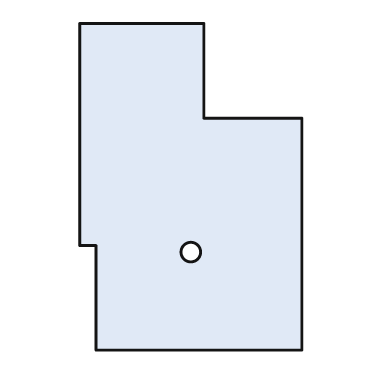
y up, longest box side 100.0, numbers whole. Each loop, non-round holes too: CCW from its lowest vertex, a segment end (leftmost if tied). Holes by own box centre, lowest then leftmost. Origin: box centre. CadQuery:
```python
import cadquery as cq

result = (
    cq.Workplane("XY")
    .moveTo(-29.0, -50.0)
    .lineTo(34.0, -50.0)
    .lineTo(34.0, 21.0)
    .lineTo(4.0, 21.0)
    .lineTo(4.0, 50.0)
    .lineTo(-34.0, 50.0)
    .lineTo(-34.0, -18.0)
    .lineTo(-29.0, -18.0)
    .close()
    .moveTo(0.0, -20.0)
    .circle(3.0)
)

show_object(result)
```